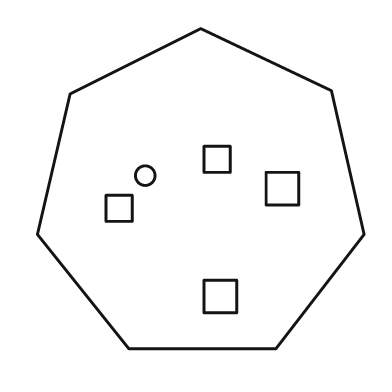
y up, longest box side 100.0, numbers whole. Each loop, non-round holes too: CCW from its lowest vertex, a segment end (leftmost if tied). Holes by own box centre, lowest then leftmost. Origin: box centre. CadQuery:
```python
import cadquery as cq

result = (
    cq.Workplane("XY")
    .moveTo(-22.0, -49.0)
    .lineTo(23.0, -49.0)
    .lineTo(50.0, -14.0)
    .lineTo(40.0, 30.0)
    .lineTo(0.0, 49.0)
    .lineTo(-40.0, 29.0)
    .lineTo(-50.0, -14.0)
    .close()
    .moveTo(1.0, -38.0)
    .lineTo(11.0, -38.0)
    .lineTo(11.0, -28.0)
    .lineTo(1.0, -28.0)
    .close()
    .moveTo(-29.0, -10.0)
    .lineTo(-21.0, -10.0)
    .lineTo(-21.0, -2.0)
    .lineTo(-29.0, -2.0)
    .close()
    .moveTo(20.0, -5.0)
    .lineTo(30.0, -5.0)
    .lineTo(30.0, 5.0)
    .lineTo(20.0, 5.0)
    .close()
    .moveTo(-17.0, 4.0)
    .circle(3.0)
    .moveTo(1.0, 5.0)
    .lineTo(9.0, 5.0)
    .lineTo(9.0, 13.0)
    .lineTo(1.0, 13.0)
    .close()
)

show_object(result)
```